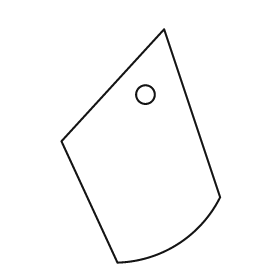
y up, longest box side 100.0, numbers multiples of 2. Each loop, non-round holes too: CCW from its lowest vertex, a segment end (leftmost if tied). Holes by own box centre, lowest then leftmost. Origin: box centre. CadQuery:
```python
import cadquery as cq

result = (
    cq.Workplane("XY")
    .moveTo(-10.0, -50.0)
    .threePointArc((16.0, -42.0), (34.0, -22.0))
    .lineTo(10.0, 50.0)
    .lineTo(-34.0, 2.0)
    .close()
    .moveTo(2.0, 22.0)
    .circle(4.0)
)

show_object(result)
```